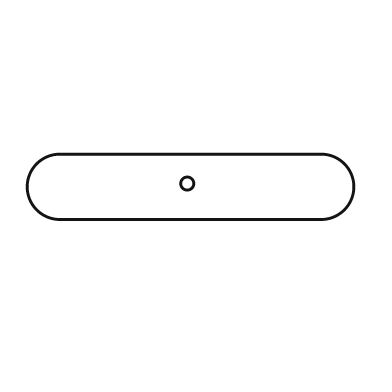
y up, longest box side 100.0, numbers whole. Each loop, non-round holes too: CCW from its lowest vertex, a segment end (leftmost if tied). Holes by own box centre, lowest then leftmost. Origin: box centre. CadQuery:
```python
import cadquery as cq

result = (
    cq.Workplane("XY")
    .moveTo(-40.0, -10.0)
    .lineTo(40.0, -10.0)
    .threePointArc((50.0, 0.0), (40.0, 10.0))
    .lineTo(-40.0, 10.0)
    .threePointArc((-50.0, 0.0), (-40.0, -10.0))
    .close()
    .moveTo(-1.0, 1.0)
    .circle(2.0)
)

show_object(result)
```